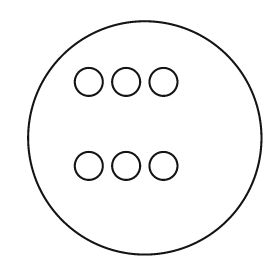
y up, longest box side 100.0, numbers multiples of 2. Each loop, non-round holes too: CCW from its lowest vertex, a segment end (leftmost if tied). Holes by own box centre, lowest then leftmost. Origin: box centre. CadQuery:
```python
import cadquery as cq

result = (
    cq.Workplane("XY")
    .moveTo(0.0, 0.0)
    .circle(50.0)
    .moveTo(-24.0, -12.0)
    .circle(6.0)
    .moveTo(-8.0, -12.0)
    .circle(6.0)
    .moveTo(8.0, -12.0)
    .circle(6.0)
    .moveTo(-24.0, 24.0)
    .circle(6.0)
    .moveTo(-8.0, 24.0)
    .circle(6.0)
    .moveTo(8.0, 24.0)
    .circle(6.0)
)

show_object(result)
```